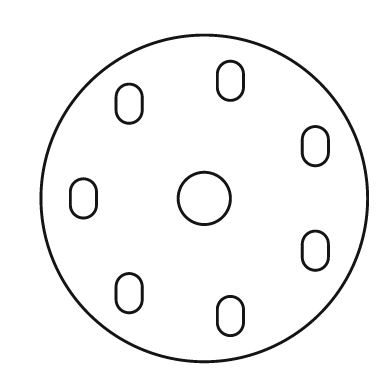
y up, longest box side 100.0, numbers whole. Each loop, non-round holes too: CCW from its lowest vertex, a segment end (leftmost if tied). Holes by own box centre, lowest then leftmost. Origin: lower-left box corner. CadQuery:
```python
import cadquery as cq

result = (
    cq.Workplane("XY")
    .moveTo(50.0, 50.0)
    .circle(50.0)
    .moveTo(54.0, 12.0)
    .threePointArc((58.0, 8.0), (62.0, 12.0))
    .lineTo(62.0, 16.0)
    .threePointArc((58.0, 20.0), (54.0, 16.0))
    .close()
    .moveTo(23.0, 19.0)
    .threePointArc((27.0, 15.0), (31.0, 19.0))
    .lineTo(31.0, 23.0)
    .threePointArc((27.0, 27.0), (23.0, 23.0))
    .close()
    .moveTo(80.0, 32.0)
    .threePointArc((84.0, 28.0), (88.0, 32.0))
    .lineTo(88.0, 36.0)
    .threePointArc((84.0, 40.0), (80.0, 36.0))
    .close()
    .moveTo(9.0, 48.0)
    .threePointArc((13.0, 44.0), (17.0, 48.0))
    .lineTo(17.0, 52.0)
    .threePointArc((13.0, 56.0), (9.0, 52.0))
    .close()
    .moveTo(50.0, 50.0)
    .circle(8.0)
    .moveTo(80.0, 64.0)
    .threePointArc((84.0, 60.0), (88.0, 64.0))
    .lineTo(88.0, 68.0)
    .threePointArc((84.0, 72.0), (80.0, 68.0))
    .close()
    .moveTo(23.0, 77.0)
    .threePointArc((27.0, 73.0), (31.0, 77.0))
    .lineTo(31.0, 81.0)
    .threePointArc((27.0, 85.0), (23.0, 81.0))
    .close()
    .moveTo(54.0, 84.0)
    .threePointArc((58.0, 80.0), (62.0, 84.0))
    .lineTo(62.0, 88.0)
    .threePointArc((58.0, 92.0), (54.0, 88.0))
    .close()
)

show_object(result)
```